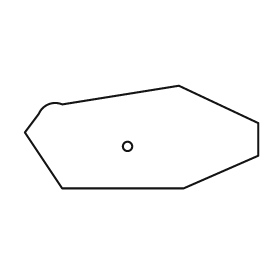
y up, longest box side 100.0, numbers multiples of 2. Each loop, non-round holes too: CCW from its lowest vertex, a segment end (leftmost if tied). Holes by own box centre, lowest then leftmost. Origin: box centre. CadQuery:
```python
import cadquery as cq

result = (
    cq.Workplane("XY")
    .moveTo(-34.0, -22.0)
    .lineTo(18.0, -22.0)
    .lineTo(50.0, -8.0)
    .lineTo(50.0, 6.0)
    .lineTo(16.0, 22.0)
    .lineTo(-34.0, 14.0)
    .threePointArc((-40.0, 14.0), (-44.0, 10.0))
    .lineTo(-50.0, 2.0)
    .close()
    .moveTo(-6.0, -4.0)
    .circle(2.0)
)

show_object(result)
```